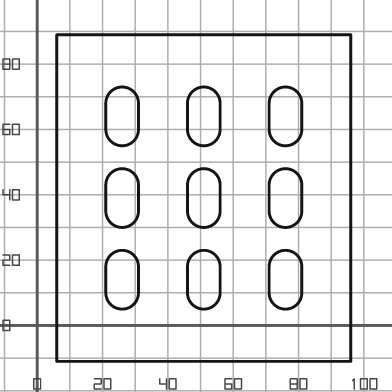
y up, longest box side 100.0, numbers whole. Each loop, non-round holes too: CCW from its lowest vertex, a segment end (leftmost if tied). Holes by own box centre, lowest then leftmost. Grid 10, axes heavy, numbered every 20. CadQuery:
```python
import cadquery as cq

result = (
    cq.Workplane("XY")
    .moveTo(6.0, -11.0)
    .lineTo(96.0, -11.0)
    .lineTo(96.0, 89.0)
    .lineTo(6.0, 89.0)
    .close()
    .moveTo(21.0, 10.0)
    .threePointArc((26.0, 5.0), (31.0, 10.0))
    .lineTo(31.0, 18.0)
    .threePointArc((26.0, 23.0), (21.0, 18.0))
    .close()
    .moveTo(46.0, 10.0)
    .threePointArc((51.0, 5.0), (56.0, 10.0))
    .lineTo(56.0, 18.0)
    .threePointArc((51.0, 23.0), (46.0, 18.0))
    .close()
    .moveTo(71.0, 10.0)
    .threePointArc((76.0, 5.0), (81.0, 10.0))
    .lineTo(81.0, 18.0)
    .threePointArc((76.0, 23.0), (71.0, 18.0))
    .close()
    .moveTo(21.0, 35.0)
    .threePointArc((26.0, 30.0), (31.0, 35.0))
    .lineTo(31.0, 43.0)
    .threePointArc((26.0, 48.0), (21.0, 43.0))
    .close()
    .moveTo(46.0, 35.0)
    .threePointArc((51.0, 30.0), (56.0, 35.0))
    .lineTo(56.0, 43.0)
    .threePointArc((51.0, 48.0), (46.0, 43.0))
    .close()
    .moveTo(71.0, 35.0)
    .threePointArc((76.0, 30.0), (81.0, 35.0))
    .lineTo(81.0, 43.0)
    .threePointArc((76.0, 48.0), (71.0, 43.0))
    .close()
    .moveTo(21.0, 60.0)
    .threePointArc((26.0, 55.0), (31.0, 60.0))
    .lineTo(31.0, 68.0)
    .threePointArc((26.0, 73.0), (21.0, 68.0))
    .close()
    .moveTo(46.0, 60.0)
    .threePointArc((51.0, 55.0), (56.0, 60.0))
    .lineTo(56.0, 68.0)
    .threePointArc((51.0, 73.0), (46.0, 68.0))
    .close()
    .moveTo(71.0, 60.0)
    .threePointArc((76.0, 55.0), (81.0, 60.0))
    .lineTo(81.0, 68.0)
    .threePointArc((76.0, 73.0), (71.0, 68.0))
    .close()
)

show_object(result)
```